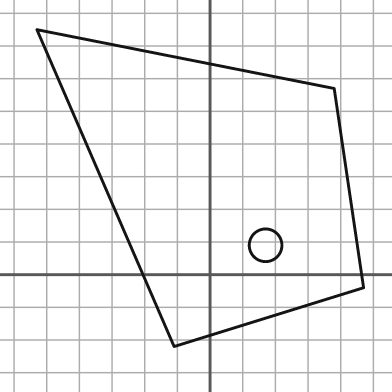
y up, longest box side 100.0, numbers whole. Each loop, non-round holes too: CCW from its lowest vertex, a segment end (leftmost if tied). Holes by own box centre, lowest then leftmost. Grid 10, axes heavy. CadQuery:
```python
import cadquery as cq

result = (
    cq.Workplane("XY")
    .moveTo(-11.0, -22.0)
    .lineTo(47.0, -4.0)
    .lineTo(38.0, 57.0)
    .lineTo(-53.0, 75.0)
    .close()
    .moveTo(17.0, 9.0)
    .circle(5.0)
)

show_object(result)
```